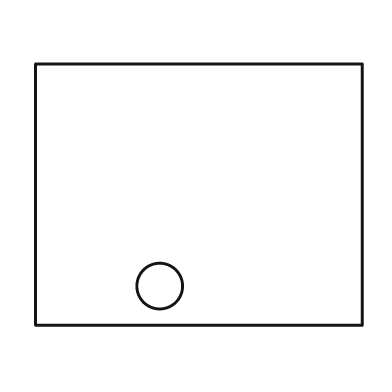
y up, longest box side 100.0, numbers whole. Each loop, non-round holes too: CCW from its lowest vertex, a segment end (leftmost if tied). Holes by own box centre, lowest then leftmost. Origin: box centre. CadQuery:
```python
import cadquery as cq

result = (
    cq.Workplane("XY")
    .moveTo(-50.0, -40.0)
    .lineTo(50.0, -40.0)
    .lineTo(50.0, 40.0)
    .lineTo(-50.0, 40.0)
    .close()
    .moveTo(-12.0, -28.0)
    .circle(7.0)
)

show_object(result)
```